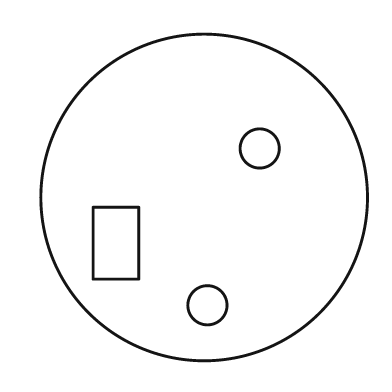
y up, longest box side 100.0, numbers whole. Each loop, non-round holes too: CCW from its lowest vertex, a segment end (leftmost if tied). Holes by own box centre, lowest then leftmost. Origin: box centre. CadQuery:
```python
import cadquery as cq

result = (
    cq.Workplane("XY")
    .moveTo(0.0, 0.0)
    .circle(50.0)
    .moveTo(1.0, -33.0)
    .circle(6.0)
    .moveTo(-34.0, -25.0)
    .lineTo(-20.0, -25.0)
    .lineTo(-20.0, -3.0)
    .lineTo(-34.0, -3.0)
    .close()
    .moveTo(17.0, 15.0)
    .circle(6.0)
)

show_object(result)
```